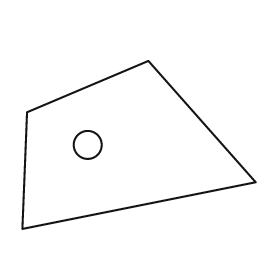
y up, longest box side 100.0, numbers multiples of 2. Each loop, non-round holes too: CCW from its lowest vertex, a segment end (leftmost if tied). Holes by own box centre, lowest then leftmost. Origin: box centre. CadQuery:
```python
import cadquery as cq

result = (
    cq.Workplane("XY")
    .moveTo(-50.0, -36.0)
    .lineTo(50.0, -16.0)
    .lineTo(4.0, 36.0)
    .lineTo(-48.0, 14.0)
    .close()
    .moveTo(-22.0, 0.0)
    .circle(6.0)
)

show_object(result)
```